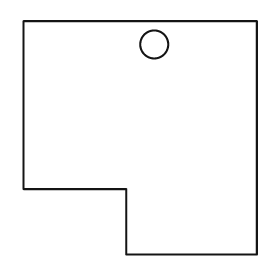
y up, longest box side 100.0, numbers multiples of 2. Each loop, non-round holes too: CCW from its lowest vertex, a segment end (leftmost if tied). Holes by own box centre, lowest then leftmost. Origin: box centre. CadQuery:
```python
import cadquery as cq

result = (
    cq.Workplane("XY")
    .moveTo(-6.0, -50.0)
    .lineTo(50.0, -50.0)
    .lineTo(50.0, 50.0)
    .lineTo(-50.0, 50.0)
    .lineTo(-50.0, -22.0)
    .lineTo(-6.0, -22.0)
    .close()
    .moveTo(6.0, 40.0)
    .circle(6.0)
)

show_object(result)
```